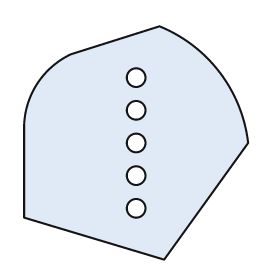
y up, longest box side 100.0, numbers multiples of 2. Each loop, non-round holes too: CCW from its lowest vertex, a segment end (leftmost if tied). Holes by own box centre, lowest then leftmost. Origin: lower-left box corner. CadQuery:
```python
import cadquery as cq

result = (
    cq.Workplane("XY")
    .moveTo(60.0, 0.0)
    .lineTo(96.0, 50.0)
    .threePointArc((84.0, 80.0), (58.0, 100.0))
    .lineTo(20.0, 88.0)
    .threePointArc((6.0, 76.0), (0.0, 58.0))
    .lineTo(0.0, 18.0)
    .close()
    .moveTo(48.0, 22.0)
    .circle(4.0)
    .moveTo(48.0, 36.0)
    .circle(4.0)
    .moveTo(48.0, 50.0)
    .circle(4.0)
    .moveTo(48.0, 64.0)
    .circle(4.0)
    .moveTo(48.0, 78.0)
    .circle(4.0)
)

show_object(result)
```